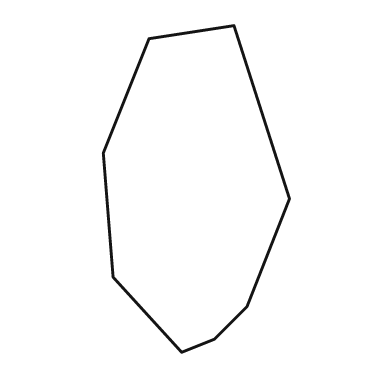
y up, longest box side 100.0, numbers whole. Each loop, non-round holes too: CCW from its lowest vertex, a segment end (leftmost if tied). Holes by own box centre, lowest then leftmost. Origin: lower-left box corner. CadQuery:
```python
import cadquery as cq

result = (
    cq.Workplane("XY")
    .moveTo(24.0, 0.0)
    .lineTo(34.0, 4.0)
    .lineTo(44.0, 14.0)
    .lineTo(57.0, 47.0)
    .lineTo(40.0, 100.0)
    .lineTo(14.0, 96.0)
    .lineTo(0.0, 61.0)
    .lineTo(3.0, 23.0)
    .close()
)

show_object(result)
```